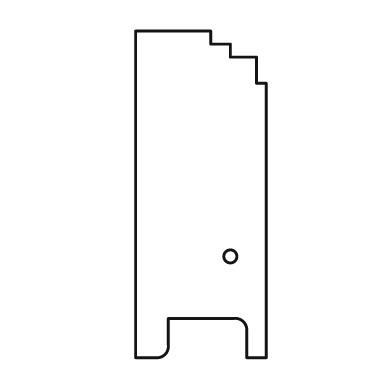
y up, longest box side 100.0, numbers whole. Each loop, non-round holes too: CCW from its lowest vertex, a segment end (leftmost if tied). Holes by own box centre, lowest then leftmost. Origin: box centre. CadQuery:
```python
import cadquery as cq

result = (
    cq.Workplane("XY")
    .moveTo(-20.0, -50.0)
    .lineTo(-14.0, -50.0)
    .threePointArc((-11.0, -49.0), (-10.0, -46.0))
    .lineTo(-10.0, -38.0)
    .lineTo(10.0, -38.0)
    .threePointArc((13.0, -39.0), (14.0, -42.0))
    .lineTo(14.0, -50.0)
    .lineTo(20.0, -50.0)
    .lineTo(20.0, 34.0)
    .lineTo(17.0, 34.0)
    .lineTo(17.0, 42.0)
    .lineTo(9.0, 42.0)
    .lineTo(9.0, 46.0)
    .lineTo(3.0, 46.0)
    .lineTo(3.0, 50.0)
    .lineTo(-20.0, 50.0)
    .close()
    .moveTo(9.0, -19.0)
    .circle(2.0)
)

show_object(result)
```